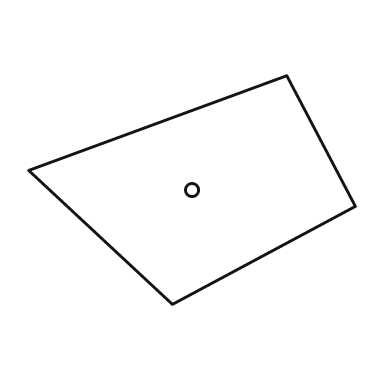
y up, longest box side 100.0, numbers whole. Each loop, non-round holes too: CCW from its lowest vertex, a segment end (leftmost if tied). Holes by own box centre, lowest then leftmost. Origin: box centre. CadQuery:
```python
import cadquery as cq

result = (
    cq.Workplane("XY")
    .moveTo(-6.0, -35.0)
    .lineTo(50.0, -5.0)
    .lineTo(29.0, 35.0)
    .lineTo(-50.0, 6.0)
    .close()
    .moveTo(0.0, 0.0)
    .circle(2.0)
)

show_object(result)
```